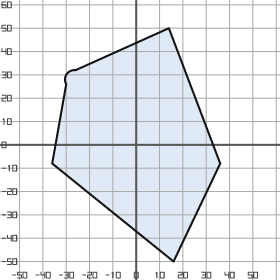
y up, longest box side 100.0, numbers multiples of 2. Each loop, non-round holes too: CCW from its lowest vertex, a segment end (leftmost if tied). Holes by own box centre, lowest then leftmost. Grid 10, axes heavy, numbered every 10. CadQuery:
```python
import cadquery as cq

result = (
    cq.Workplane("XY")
    .moveTo(16.0, -50.0)
    .lineTo(36.0, -8.0)
    .lineTo(14.0, 50.0)
    .lineTo(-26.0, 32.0)
    .threePointArc((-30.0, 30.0), (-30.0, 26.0))
    .lineTo(-36.0, -8.0)
    .close()
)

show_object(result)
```